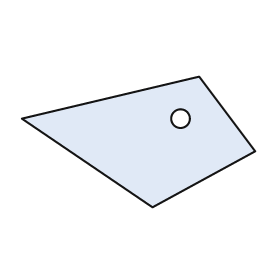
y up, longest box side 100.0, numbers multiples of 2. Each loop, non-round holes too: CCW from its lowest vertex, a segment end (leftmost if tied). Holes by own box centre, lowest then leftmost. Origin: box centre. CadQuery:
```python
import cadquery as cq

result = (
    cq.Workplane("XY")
    .moveTo(6.0, -28.0)
    .lineTo(50.0, -4.0)
    .lineTo(26.0, 28.0)
    .lineTo(-50.0, 10.0)
    .close()
    .moveTo(18.0, 10.0)
    .circle(4.0)
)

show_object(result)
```